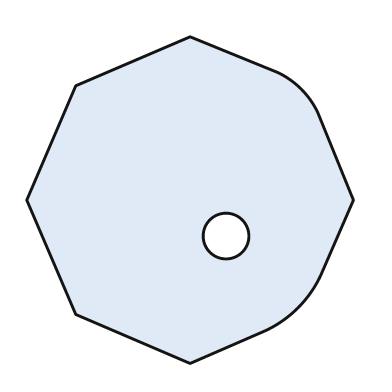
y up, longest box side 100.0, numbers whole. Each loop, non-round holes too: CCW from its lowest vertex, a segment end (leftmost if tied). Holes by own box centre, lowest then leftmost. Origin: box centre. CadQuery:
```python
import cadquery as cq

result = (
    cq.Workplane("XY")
    .moveTo(0.0, -50.0)
    .lineTo(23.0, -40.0)
    .threePointArc((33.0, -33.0), (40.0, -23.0))
    .lineTo(50.0, 0.0)
    .lineTo(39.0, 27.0)
    .threePointArc((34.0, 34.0), (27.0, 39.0))
    .lineTo(0.0, 50.0)
    .lineTo(-35.0, 35.0)
    .lineTo(-50.0, 0.0)
    .lineTo(-35.0, -35.0)
    .close()
    .moveTo(11.0, -11.0)
    .circle(7.0)
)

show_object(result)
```